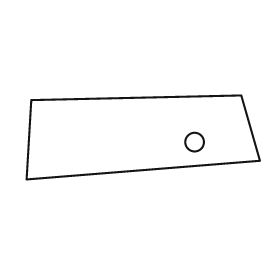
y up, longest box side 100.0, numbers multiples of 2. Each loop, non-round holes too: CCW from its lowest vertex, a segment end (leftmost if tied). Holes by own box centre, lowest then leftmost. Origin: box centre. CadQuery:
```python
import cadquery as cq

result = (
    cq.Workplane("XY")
    .moveTo(-50.0, -18.0)
    .lineTo(50.0, -10.0)
    .lineTo(42.0, 18.0)
    .lineTo(-48.0, 16.0)
    .close()
    .moveTo(22.0, -2.0)
    .circle(4.0)
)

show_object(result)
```